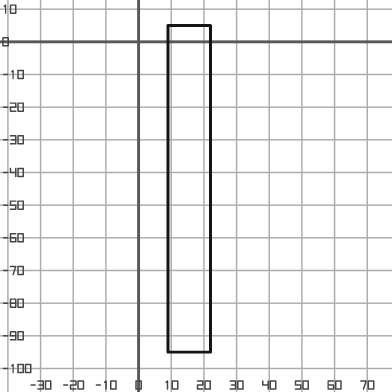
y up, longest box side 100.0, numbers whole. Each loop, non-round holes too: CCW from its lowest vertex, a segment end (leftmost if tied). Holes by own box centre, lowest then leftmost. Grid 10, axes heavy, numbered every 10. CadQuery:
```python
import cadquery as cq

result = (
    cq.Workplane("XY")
    .moveTo(9.0, -95.0)
    .lineTo(22.0, -95.0)
    .lineTo(22.0, 5.0)
    .lineTo(9.0, 5.0)
    .close()
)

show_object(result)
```